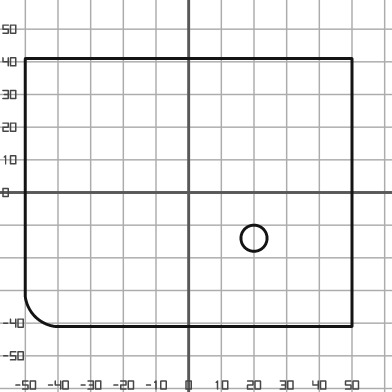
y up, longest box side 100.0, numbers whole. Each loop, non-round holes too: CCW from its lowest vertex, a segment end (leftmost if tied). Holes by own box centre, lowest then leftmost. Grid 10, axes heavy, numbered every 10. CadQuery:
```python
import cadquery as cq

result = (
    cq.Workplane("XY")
    .moveTo(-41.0, -41.0)
    .lineTo(50.0, -41.0)
    .lineTo(50.0, 41.0)
    .lineTo(-50.0, 41.0)
    .lineTo(-50.0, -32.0)
    .threePointArc((-47.0, -38.0), (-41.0, -41.0))
    .close()
    .moveTo(20.0, -14.0)
    .circle(4.0)
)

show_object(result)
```